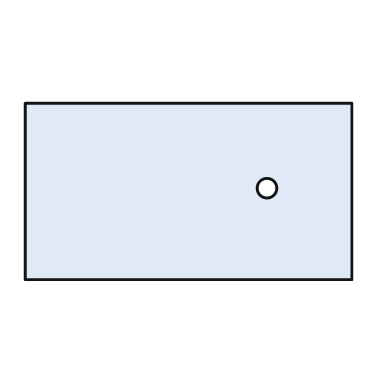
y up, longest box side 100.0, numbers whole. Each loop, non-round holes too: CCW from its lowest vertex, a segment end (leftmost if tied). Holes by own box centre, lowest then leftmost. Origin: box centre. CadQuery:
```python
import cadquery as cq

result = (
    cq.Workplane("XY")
    .moveTo(-50.0, -27.0)
    .lineTo(50.0, -27.0)
    .lineTo(50.0, 27.0)
    .lineTo(-50.0, 27.0)
    .close()
    .moveTo(24.0, 1.0)
    .circle(3.0)
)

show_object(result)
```